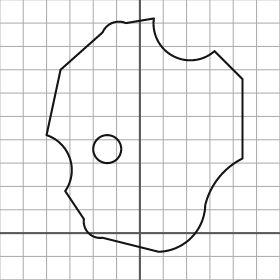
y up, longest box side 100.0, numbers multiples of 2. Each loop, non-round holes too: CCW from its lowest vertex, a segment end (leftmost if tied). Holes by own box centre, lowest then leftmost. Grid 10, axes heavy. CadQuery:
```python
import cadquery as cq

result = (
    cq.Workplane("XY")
    .moveTo(8.0, -8.0)
    .threePointArc((22.0, -2.0), (28.0, 12.0))
    .threePointArc((34.0, 24.0), (44.0, 32.0))
    .lineTo(44.0, 66.0)
    .lineTo(32.0, 78.0)
    .threePointArc((14.0, 76.0), (6.0, 92.0))
    .lineTo(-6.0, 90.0)
    .threePointArc((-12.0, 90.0), (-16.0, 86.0))
    .lineTo(-34.0, 70.0)
    .lineTo(-40.0, 42.0)
    .threePointArc((-30.0, 32.0), (-32.0, 18.0))
    .lineTo(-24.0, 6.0)
    .threePointArc((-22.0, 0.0), (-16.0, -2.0))
    .close()
    .moveTo(-14.0, 36.0)
    .circle(6.0)
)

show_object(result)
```